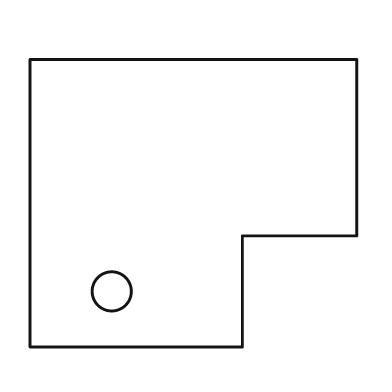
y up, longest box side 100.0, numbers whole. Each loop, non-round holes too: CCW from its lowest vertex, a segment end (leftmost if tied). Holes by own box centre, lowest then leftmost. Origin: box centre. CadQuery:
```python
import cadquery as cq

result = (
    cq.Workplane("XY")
    .moveTo(-50.0, -44.0)
    .lineTo(15.0, -44.0)
    .lineTo(15.0, -10.0)
    .lineTo(50.0, -10.0)
    .lineTo(50.0, 44.0)
    .lineTo(-50.0, 44.0)
    .close()
    .moveTo(-25.0, -27.0)
    .circle(6.0)
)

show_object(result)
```